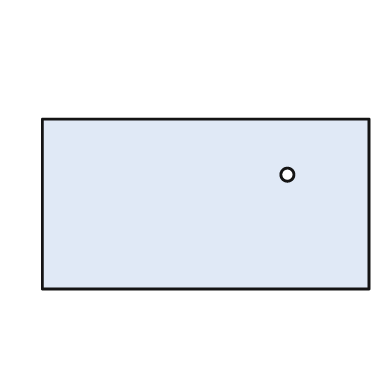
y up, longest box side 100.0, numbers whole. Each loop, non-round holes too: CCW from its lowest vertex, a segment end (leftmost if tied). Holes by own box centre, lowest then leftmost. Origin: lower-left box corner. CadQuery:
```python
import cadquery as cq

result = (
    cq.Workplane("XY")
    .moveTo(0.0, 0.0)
    .lineTo(100.0, 0.0)
    .lineTo(100.0, 52.0)
    .lineTo(0.0, 52.0)
    .close()
    .moveTo(75.0, 35.0)
    .circle(2.0)
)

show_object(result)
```